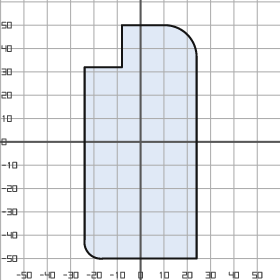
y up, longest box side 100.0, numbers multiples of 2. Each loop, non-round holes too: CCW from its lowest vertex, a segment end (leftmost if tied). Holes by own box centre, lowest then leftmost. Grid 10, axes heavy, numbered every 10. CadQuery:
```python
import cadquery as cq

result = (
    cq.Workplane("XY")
    .moveTo(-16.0, -50.0)
    .lineTo(24.0, -50.0)
    .lineTo(24.0, 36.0)
    .threePointArc((20.0, 46.0), (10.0, 50.0))
    .lineTo(-8.0, 50.0)
    .lineTo(-8.0, 32.0)
    .lineTo(-24.0, 32.0)
    .lineTo(-24.0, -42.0)
    .threePointArc((-22.0, -48.0), (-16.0, -50.0))
    .close()
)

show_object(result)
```